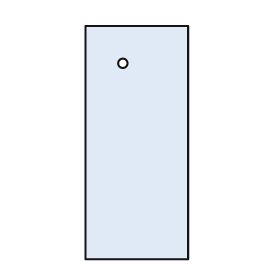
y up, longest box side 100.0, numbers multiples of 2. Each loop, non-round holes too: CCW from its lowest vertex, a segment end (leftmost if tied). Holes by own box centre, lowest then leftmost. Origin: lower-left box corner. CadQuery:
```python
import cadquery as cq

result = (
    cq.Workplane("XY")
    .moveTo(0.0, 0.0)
    .lineTo(44.0, 0.0)
    .lineTo(44.0, 100.0)
    .lineTo(0.0, 100.0)
    .close()
    .moveTo(16.0, 84.0)
    .circle(2.0)
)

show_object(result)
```